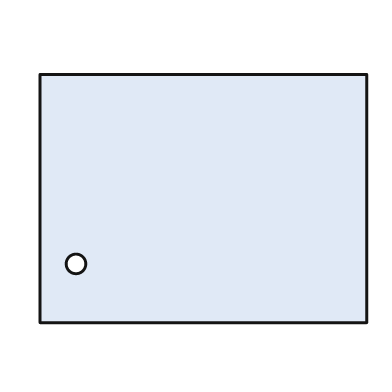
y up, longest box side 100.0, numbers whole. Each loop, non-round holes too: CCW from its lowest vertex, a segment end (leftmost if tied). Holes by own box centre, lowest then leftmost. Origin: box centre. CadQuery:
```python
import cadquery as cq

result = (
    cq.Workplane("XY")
    .moveTo(-50.0, -38.0)
    .lineTo(50.0, -38.0)
    .lineTo(50.0, 38.0)
    .lineTo(-50.0, 38.0)
    .close()
    .moveTo(-39.0, -20.0)
    .circle(3.0)
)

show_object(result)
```